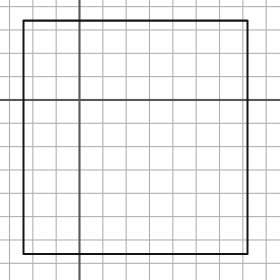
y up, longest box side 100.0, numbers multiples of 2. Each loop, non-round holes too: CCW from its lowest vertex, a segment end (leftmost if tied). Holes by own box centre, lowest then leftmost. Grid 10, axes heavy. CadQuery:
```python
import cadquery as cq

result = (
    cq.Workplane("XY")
    .moveTo(-24.0, -66.0)
    .lineTo(72.0, -66.0)
    .lineTo(72.0, 34.0)
    .lineTo(-24.0, 34.0)
    .close()
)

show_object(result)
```